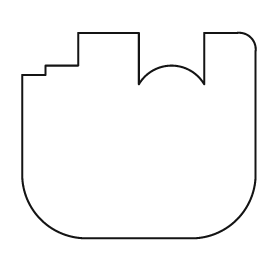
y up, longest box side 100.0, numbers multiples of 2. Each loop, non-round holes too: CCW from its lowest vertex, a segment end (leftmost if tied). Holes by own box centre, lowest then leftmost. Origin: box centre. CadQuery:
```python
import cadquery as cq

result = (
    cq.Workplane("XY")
    .moveTo(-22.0, -44.0)
    .lineTo(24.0, -44.0)
    .threePointArc((42.0, -36.0), (50.0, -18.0))
    .lineTo(50.0, 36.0)
    .threePointArc((48.0, 42.0), (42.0, 44.0))
    .lineTo(28.0, 44.0)
    .lineTo(28.0, 22.0)
    .threePointArc((14.0, 30.0), (0.0, 22.0))
    .lineTo(0.0, 44.0)
    .lineTo(-26.0, 44.0)
    .lineTo(-26.0, 30.0)
    .lineTo(-40.0, 30.0)
    .lineTo(-40.0, 26.0)
    .lineTo(-50.0, 26.0)
    .lineTo(-50.0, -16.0)
    .threePointArc((-42.0, -36.0), (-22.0, -44.0))
    .close()
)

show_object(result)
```